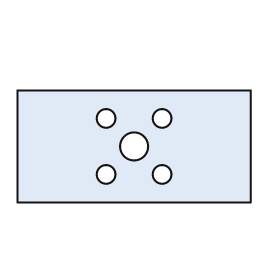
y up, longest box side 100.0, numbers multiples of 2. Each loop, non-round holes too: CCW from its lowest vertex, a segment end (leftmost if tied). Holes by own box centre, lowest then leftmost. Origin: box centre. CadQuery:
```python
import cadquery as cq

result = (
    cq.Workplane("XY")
    .moveTo(-50.0, -24.0)
    .lineTo(50.0, -24.0)
    .lineTo(50.0, 24.0)
    .lineTo(-50.0, 24.0)
    .close()
    .moveTo(-12.0, -12.0)
    .circle(4.0)
    .moveTo(12.0, -12.0)
    .circle(4.0)
    .moveTo(0.0, 0.0)
    .circle(6.0)
    .moveTo(-12.0, 12.0)
    .circle(4.0)
    .moveTo(12.0, 12.0)
    .circle(4.0)
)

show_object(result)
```